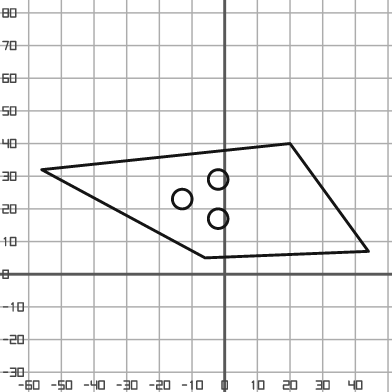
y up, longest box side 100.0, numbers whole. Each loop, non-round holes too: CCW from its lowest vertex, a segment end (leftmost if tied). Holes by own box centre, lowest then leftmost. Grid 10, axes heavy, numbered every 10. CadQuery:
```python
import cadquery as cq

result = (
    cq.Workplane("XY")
    .moveTo(-6.0, 5.0)
    .lineTo(44.0, 7.0)
    .lineTo(20.0, 40.0)
    .lineTo(-56.0, 32.0)
    .close()
    .moveTo(-2.0, 17.0)
    .circle(3.0)
    .moveTo(-13.0, 23.0)
    .circle(3.0)
    .moveTo(-2.0, 29.0)
    .circle(3.0)
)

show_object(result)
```